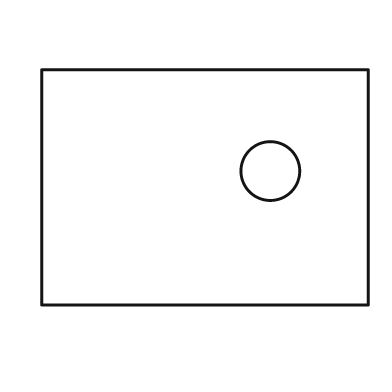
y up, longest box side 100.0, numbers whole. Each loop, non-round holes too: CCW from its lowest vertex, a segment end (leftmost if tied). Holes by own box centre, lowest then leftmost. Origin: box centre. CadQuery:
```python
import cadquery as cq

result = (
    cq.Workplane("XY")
    .moveTo(-50.0, -36.0)
    .lineTo(50.0, -36.0)
    .lineTo(50.0, 36.0)
    .lineTo(-50.0, 36.0)
    .close()
    .moveTo(20.0, 5.0)
    .circle(9.0)
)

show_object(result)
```